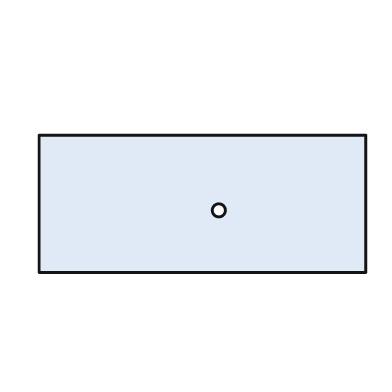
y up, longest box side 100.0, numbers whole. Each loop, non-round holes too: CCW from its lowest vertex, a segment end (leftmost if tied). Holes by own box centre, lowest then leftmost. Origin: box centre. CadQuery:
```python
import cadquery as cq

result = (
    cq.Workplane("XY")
    .moveTo(-50.0, -21.0)
    .lineTo(50.0, -21.0)
    .lineTo(50.0, 21.0)
    .lineTo(-50.0, 21.0)
    .close()
    .moveTo(5.0, -2.0)
    .circle(2.0)
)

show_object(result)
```